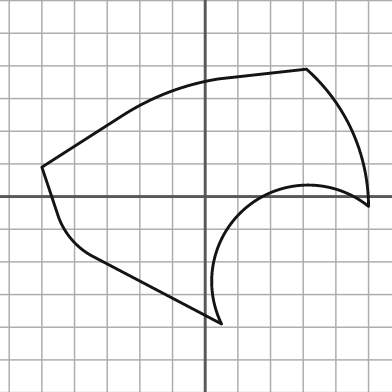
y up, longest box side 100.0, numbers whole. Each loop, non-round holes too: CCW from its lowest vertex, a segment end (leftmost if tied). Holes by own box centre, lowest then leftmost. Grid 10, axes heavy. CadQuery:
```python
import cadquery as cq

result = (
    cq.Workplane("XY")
    .moveTo(5.0, -39.0)
    .threePointArc((13.0, -3.0), (50.0, -3.0))
    .threePointArc((45.0, 20.0), (31.0, 39.0))
    .lineTo(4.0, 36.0)
    .threePointArc((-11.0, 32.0), (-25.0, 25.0))
    .lineTo(-50.0, 9.0)
    .lineTo(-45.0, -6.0)
    .threePointArc((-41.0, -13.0), (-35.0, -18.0))
    .close()
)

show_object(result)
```